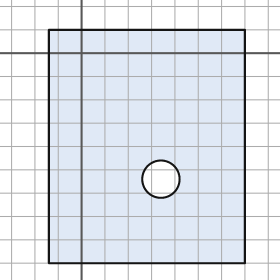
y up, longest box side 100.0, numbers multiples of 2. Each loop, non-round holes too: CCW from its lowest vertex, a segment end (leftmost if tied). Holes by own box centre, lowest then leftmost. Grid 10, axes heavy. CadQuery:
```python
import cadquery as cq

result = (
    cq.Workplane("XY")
    .moveTo(-14.0, -90.0)
    .lineTo(70.0, -90.0)
    .lineTo(70.0, 10.0)
    .lineTo(-14.0, 10.0)
    .close()
    .moveTo(34.0, -54.0)
    .circle(8.0)
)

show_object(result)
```